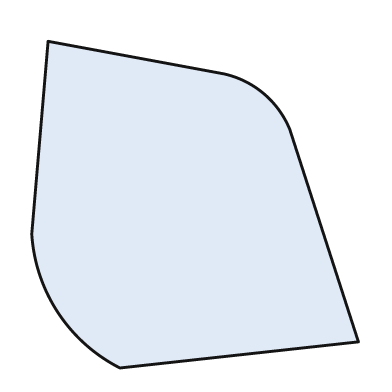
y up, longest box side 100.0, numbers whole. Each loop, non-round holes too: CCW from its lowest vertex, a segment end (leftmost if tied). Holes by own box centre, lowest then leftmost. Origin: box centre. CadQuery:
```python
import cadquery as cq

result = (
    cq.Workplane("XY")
    .moveTo(-23.0, -50.0)
    .lineTo(50.0, -42.0)
    .lineTo(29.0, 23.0)
    .threePointArc((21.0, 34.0), (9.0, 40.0))
    .lineTo(-45.0, 50.0)
    .lineTo(-50.0, -9.0)
    .threePointArc((-42.0, -33.0), (-23.0, -50.0))
    .close()
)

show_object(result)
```